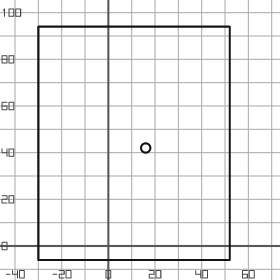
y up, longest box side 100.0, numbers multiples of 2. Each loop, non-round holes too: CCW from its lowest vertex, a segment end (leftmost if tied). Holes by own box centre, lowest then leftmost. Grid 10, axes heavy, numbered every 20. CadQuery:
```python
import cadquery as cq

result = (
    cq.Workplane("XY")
    .moveTo(-30.0, -6.0)
    .lineTo(52.0, -6.0)
    .lineTo(52.0, 94.0)
    .lineTo(-30.0, 94.0)
    .close()
    .moveTo(16.0, 42.0)
    .circle(2.0)
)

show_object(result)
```